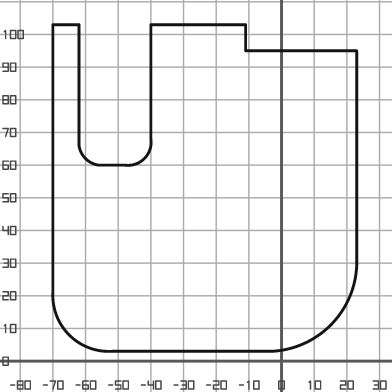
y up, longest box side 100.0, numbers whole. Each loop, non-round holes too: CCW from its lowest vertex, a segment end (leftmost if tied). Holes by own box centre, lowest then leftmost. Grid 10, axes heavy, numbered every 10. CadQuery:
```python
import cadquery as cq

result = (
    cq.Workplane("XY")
    .moveTo(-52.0, 3.0)
    .lineTo(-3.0, 3.0)
    .threePointArc((15.0, 11.0), (23.0, 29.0))
    .lineTo(23.0, 95.0)
    .lineTo(-11.0, 95.0)
    .lineTo(-11.0, 103.0)
    .lineTo(-40.0, 103.0)
    .lineTo(-40.0, 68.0)
    .threePointArc((-42.0, 62.0), (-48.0, 60.0))
    .lineTo(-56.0, 60.0)
    .threePointArc((-60.0, 62.0), (-62.0, 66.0))
    .lineTo(-62.0, 103.0)
    .lineTo(-70.0, 103.0)
    .lineTo(-70.0, 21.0)
    .threePointArc((-65.0, 8.0), (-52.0, 3.0))
    .close()
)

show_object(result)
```